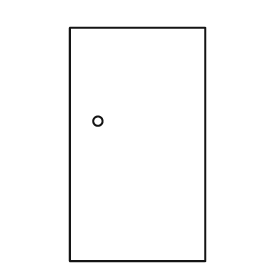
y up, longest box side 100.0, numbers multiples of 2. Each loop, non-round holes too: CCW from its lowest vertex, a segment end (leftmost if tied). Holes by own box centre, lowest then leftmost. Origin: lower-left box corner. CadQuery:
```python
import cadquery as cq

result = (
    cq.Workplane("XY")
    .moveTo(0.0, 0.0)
    .lineTo(58.0, 0.0)
    .lineTo(58.0, 100.0)
    .lineTo(0.0, 100.0)
    .close()
    .moveTo(12.0, 60.0)
    .circle(2.0)
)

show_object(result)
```